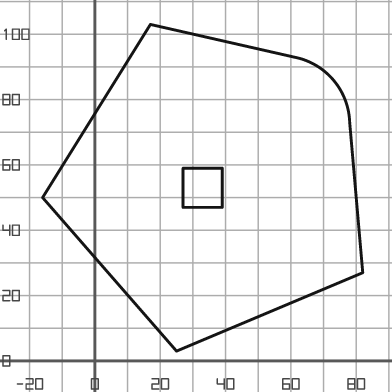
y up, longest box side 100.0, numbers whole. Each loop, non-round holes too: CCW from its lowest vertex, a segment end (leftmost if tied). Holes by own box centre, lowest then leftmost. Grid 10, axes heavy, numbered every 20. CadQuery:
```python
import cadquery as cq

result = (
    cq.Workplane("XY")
    .moveTo(25.0, 3.0)
    .lineTo(82.0, 27.0)
    .lineTo(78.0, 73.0)
    .threePointArc((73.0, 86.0), (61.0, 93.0))
    .lineTo(17.0, 103.0)
    .lineTo(-16.0, 50.0)
    .close()
    .moveTo(27.0, 47.0)
    .lineTo(39.0, 47.0)
    .lineTo(39.0, 59.0)
    .lineTo(27.0, 59.0)
    .close()
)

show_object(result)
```